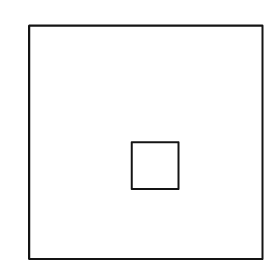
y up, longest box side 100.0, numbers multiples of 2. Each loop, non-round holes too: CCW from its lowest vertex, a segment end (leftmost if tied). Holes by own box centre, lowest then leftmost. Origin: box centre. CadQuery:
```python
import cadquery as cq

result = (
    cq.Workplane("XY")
    .moveTo(-50.0, -50.0)
    .lineTo(50.0, -50.0)
    .lineTo(50.0, 50.0)
    .lineTo(-50.0, 50.0)
    .close()
    .moveTo(-6.0, -20.0)
    .lineTo(14.0, -20.0)
    .lineTo(14.0, 0.0)
    .lineTo(-6.0, 0.0)
    .close()
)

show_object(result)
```